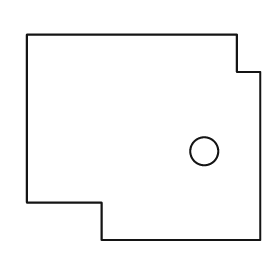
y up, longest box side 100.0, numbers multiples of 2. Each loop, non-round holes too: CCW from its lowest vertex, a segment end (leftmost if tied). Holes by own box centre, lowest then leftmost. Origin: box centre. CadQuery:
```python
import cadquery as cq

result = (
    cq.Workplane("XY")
    .moveTo(-18.0, -44.0)
    .lineTo(50.0, -44.0)
    .lineTo(50.0, 28.0)
    .lineTo(40.0, 28.0)
    .lineTo(40.0, 44.0)
    .lineTo(-50.0, 44.0)
    .lineTo(-50.0, -28.0)
    .lineTo(-18.0, -28.0)
    .close()
    .moveTo(26.0, -6.0)
    .circle(6.0)
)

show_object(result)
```